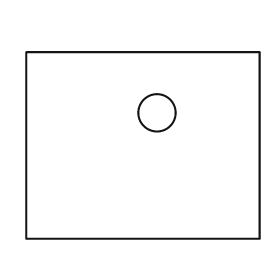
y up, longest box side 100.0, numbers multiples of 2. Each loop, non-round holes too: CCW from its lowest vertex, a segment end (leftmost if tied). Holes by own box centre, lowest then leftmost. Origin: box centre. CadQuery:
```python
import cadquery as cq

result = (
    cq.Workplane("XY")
    .moveTo(-50.0, -40.0)
    .lineTo(50.0, -40.0)
    .lineTo(50.0, 40.0)
    .lineTo(-50.0, 40.0)
    .close()
    .moveTo(6.0, 14.0)
    .circle(8.0)
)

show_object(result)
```